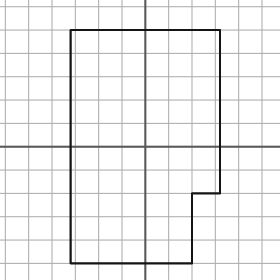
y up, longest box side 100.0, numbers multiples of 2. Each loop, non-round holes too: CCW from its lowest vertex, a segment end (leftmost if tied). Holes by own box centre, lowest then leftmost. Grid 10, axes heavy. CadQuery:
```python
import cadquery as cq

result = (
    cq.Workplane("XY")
    .moveTo(-32.0, -50.0)
    .lineTo(20.0, -50.0)
    .lineTo(20.0, -20.0)
    .lineTo(32.0, -20.0)
    .lineTo(32.0, 50.0)
    .lineTo(-32.0, 50.0)
    .close()
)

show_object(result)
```